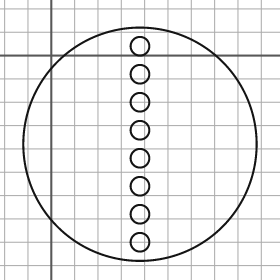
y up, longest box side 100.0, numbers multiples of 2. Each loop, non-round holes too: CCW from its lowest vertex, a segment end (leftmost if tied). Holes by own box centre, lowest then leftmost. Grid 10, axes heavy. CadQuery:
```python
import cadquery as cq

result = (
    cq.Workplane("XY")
    .moveTo(38.0, -38.0)
    .circle(50.0)
    .moveTo(38.0, -80.0)
    .circle(4.0)
    .moveTo(38.0, -68.0)
    .circle(4.0)
    .moveTo(38.0, -56.0)
    .circle(4.0)
    .moveTo(38.0, -44.0)
    .circle(4.0)
    .moveTo(38.0, -32.0)
    .circle(4.0)
    .moveTo(38.0, -20.0)
    .circle(4.0)
    .moveTo(38.0, -8.0)
    .circle(4.0)
    .moveTo(38.0, 4.0)
    .circle(4.0)
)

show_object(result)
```